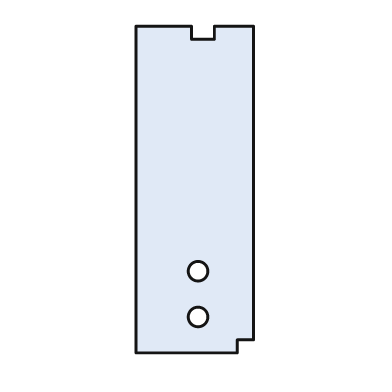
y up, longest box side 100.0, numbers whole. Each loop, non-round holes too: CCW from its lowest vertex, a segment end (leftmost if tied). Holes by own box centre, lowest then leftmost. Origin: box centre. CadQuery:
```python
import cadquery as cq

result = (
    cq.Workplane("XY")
    .moveTo(-18.0, -50.0)
    .lineTo(13.0, -50.0)
    .lineTo(13.0, -46.0)
    .lineTo(18.0, -46.0)
    .lineTo(18.0, 50.0)
    .lineTo(6.0, 50.0)
    .lineTo(6.0, 46.0)
    .lineTo(-1.0, 46.0)
    .lineTo(-1.0, 50.0)
    .lineTo(-18.0, 50.0)
    .close()
    .moveTo(1.0, -39.0)
    .circle(3.0)
    .moveTo(1.0, -25.0)
    .circle(3.0)
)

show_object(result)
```